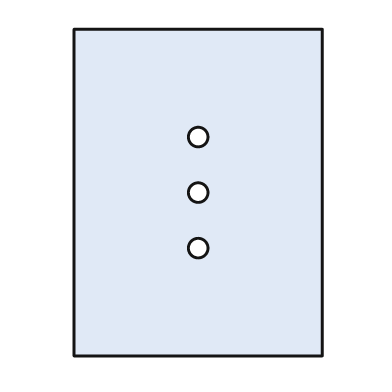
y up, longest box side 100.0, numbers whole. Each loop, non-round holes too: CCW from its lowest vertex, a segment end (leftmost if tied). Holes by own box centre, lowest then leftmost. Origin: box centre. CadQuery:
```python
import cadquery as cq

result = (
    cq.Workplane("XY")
    .moveTo(-38.0, -50.0)
    .lineTo(38.0, -50.0)
    .lineTo(38.0, 50.0)
    .lineTo(-38.0, 50.0)
    .close()
    .moveTo(0.0, -17.0)
    .circle(3.0)
    .moveTo(0.0, 0.0)
    .circle(3.0)
    .moveTo(0.0, 17.0)
    .circle(3.0)
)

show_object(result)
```